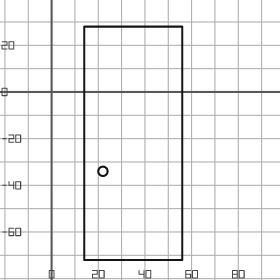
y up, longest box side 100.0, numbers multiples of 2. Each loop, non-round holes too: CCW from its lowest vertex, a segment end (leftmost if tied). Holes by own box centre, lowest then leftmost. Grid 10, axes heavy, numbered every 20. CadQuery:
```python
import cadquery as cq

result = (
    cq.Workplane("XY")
    .moveTo(14.0, -72.0)
    .lineTo(56.0, -72.0)
    .lineTo(56.0, 28.0)
    .lineTo(14.0, 28.0)
    .close()
    .moveTo(22.0, -34.0)
    .circle(2.0)
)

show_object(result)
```